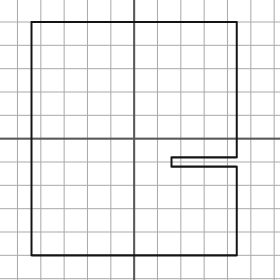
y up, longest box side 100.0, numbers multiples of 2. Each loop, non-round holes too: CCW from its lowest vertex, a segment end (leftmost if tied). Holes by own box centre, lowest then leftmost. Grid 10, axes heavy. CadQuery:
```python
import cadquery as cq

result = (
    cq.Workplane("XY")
    .moveTo(-44.0, -50.0)
    .lineTo(44.0, -50.0)
    .lineTo(44.0, -12.0)
    .lineTo(16.0, -12.0)
    .lineTo(16.0, -8.0)
    .lineTo(44.0, -8.0)
    .lineTo(44.0, 50.0)
    .lineTo(-44.0, 50.0)
    .close()
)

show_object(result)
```